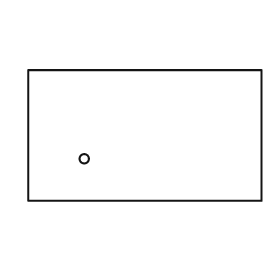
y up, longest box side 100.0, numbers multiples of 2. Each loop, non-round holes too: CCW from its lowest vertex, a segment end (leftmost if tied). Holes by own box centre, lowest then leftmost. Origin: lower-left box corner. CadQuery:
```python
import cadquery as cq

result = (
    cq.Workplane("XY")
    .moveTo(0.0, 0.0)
    .lineTo(100.0, 0.0)
    .lineTo(100.0, 56.0)
    .lineTo(0.0, 56.0)
    .close()
    .moveTo(24.0, 18.0)
    .circle(2.0)
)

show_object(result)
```